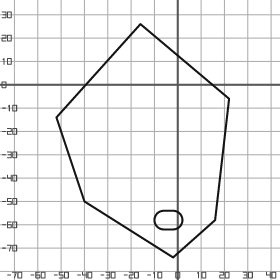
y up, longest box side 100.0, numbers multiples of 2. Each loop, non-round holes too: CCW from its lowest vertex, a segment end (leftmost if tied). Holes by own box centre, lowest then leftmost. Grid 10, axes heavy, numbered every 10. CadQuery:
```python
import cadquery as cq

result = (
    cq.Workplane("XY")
    .moveTo(-2.0, -74.0)
    .lineTo(16.0, -58.0)
    .lineTo(22.0, -6.0)
    .lineTo(-16.0, 26.0)
    .lineTo(-52.0, -14.0)
    .lineTo(-40.0, -50.0)
    .close()
    .moveTo(-6.0, -62.0)
    .lineTo(-2.0, -62.0)
    .threePointArc((2.0, -58.0), (-2.0, -54.0))
    .lineTo(-6.0, -54.0)
    .threePointArc((-10.0, -58.0), (-6.0, -62.0))
    .close()
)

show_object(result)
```